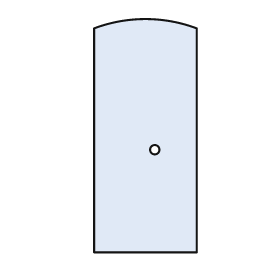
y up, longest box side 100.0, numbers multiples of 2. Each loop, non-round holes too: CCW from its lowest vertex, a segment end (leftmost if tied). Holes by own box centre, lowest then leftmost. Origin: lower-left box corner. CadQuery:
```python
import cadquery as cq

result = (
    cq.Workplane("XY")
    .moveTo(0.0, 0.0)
    .lineTo(44.0, 0.0)
    .lineTo(44.0, 96.0)
    .threePointArc((22.0, 100.0), (0.0, 96.0))
    .close()
    .moveTo(26.0, 44.0)
    .circle(2.0)
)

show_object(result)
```